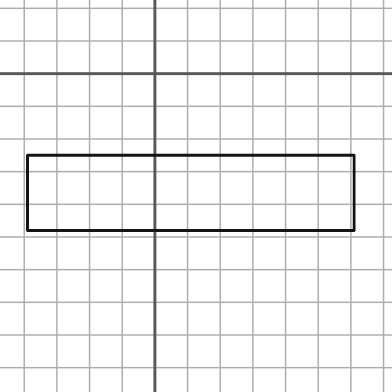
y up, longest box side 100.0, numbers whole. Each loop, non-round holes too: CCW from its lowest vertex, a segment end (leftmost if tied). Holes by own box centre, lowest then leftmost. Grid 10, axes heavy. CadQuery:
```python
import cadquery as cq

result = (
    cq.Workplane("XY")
    .moveTo(-39.0, -48.0)
    .lineTo(61.0, -48.0)
    .lineTo(61.0, -25.0)
    .lineTo(-39.0, -25.0)
    .close()
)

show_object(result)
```